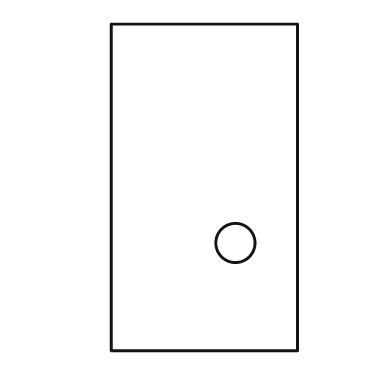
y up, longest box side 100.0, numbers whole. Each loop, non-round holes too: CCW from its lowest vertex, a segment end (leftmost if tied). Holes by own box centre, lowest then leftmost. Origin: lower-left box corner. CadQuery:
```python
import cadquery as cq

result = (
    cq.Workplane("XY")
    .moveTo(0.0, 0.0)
    .lineTo(57.0, 0.0)
    .lineTo(57.0, 100.0)
    .lineTo(0.0, 100.0)
    .close()
    .moveTo(38.0, 33.0)
    .circle(6.0)
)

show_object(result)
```